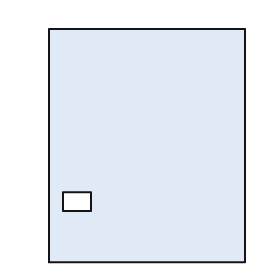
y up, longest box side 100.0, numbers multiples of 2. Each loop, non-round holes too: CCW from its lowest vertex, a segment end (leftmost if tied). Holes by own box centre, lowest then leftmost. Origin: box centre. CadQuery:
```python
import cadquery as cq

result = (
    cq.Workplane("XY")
    .moveTo(-42.0, -50.0)
    .lineTo(42.0, -50.0)
    .lineTo(42.0, 50.0)
    .lineTo(-42.0, 50.0)
    .close()
    .moveTo(-36.0, -28.0)
    .lineTo(-24.0, -28.0)
    .lineTo(-24.0, -20.0)
    .lineTo(-36.0, -20.0)
    .close()
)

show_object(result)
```